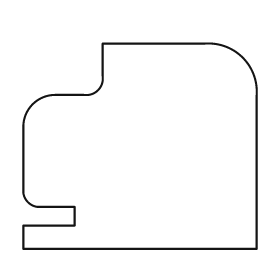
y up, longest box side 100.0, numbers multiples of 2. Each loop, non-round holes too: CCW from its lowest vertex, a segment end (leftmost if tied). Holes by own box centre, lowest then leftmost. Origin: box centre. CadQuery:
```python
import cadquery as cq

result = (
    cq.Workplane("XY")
    .moveTo(-50.0, -44.0)
    .lineTo(50.0, -44.0)
    .lineTo(50.0, 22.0)
    .threePointArc((44.0, 38.0), (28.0, 44.0))
    .lineTo(-16.0, 44.0)
    .lineTo(-16.0, 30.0)
    .threePointArc((-18.0, 24.0), (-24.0, 22.0))
    .lineTo(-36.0, 22.0)
    .threePointArc((-46.0, 18.0), (-50.0, 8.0))
    .lineTo(-50.0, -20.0)
    .threePointArc((-48.0, -24.0), (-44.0, -26.0))
    .lineTo(-28.0, -26.0)
    .lineTo(-28.0, -34.0)
    .lineTo(-50.0, -34.0)
    .close()
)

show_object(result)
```